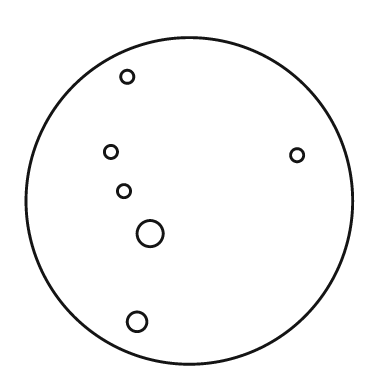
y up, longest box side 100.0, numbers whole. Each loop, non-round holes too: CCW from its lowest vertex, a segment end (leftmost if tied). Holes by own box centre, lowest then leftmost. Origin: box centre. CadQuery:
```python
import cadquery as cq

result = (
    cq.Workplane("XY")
    .moveTo(0.0, 0.0)
    .circle(50.0)
    .moveTo(-16.0, -37.0)
    .circle(3.0)
    .moveTo(-12.0, -10.0)
    .circle(4.0)
    .moveTo(-20.0, 3.0)
    .circle(2.0)
    .moveTo(33.0, 14.0)
    .circle(2.0)
    .moveTo(-24.0, 15.0)
    .circle(2.0)
    .moveTo(-19.0, 38.0)
    .circle(2.0)
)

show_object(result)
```